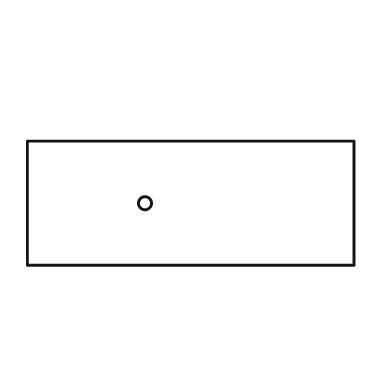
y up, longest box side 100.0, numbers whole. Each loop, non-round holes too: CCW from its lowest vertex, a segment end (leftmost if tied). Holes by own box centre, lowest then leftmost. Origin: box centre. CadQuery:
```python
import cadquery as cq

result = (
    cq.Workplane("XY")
    .moveTo(-50.0, -19.0)
    .lineTo(50.0, -19.0)
    .lineTo(50.0, 19.0)
    .lineTo(-50.0, 19.0)
    .close()
    .moveTo(-14.0, 0.0)
    .circle(2.0)
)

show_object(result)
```